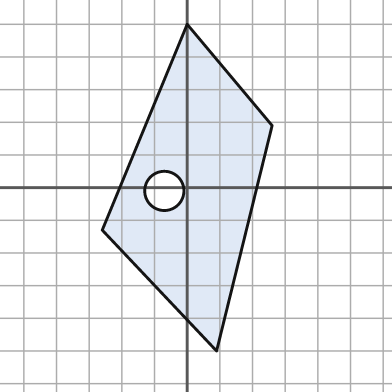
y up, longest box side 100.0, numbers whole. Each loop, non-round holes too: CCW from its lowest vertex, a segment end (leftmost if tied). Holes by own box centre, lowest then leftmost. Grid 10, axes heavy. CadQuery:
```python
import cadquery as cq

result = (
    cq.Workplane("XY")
    .moveTo(9.0, -50.0)
    .lineTo(26.0, 19.0)
    .lineTo(0.0, 50.0)
    .lineTo(-26.0, -13.0)
    .close()
    .moveTo(-7.0, -1.0)
    .circle(6.0)
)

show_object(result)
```